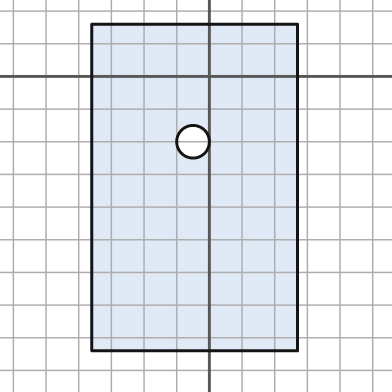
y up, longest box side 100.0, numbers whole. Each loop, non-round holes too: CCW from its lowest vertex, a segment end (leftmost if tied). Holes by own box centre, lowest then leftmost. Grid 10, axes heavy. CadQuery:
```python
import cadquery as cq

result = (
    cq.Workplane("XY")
    .moveTo(-36.0, -84.0)
    .lineTo(27.0, -84.0)
    .lineTo(27.0, 16.0)
    .lineTo(-36.0, 16.0)
    .close()
    .moveTo(-5.0, -20.0)
    .circle(5.0)
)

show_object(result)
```